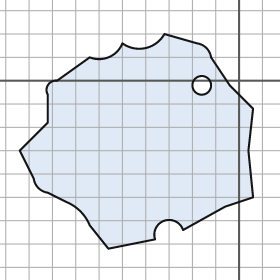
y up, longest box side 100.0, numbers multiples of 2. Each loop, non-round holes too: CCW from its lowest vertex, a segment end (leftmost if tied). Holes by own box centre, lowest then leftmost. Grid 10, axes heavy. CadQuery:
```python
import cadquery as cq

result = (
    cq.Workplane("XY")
    .moveTo(-56.0, -72.0)
    .lineTo(-36.0, -68.0)
    .threePointArc((-32.0, -60.0), (-24.0, -64.0))
    .lineTo(-6.0, -54.0)
    .lineTo(6.0, -50.0)
    .lineTo(4.0, -30.0)
    .lineTo(6.0, -12.0)
    .lineTo(-4.0, -2.0)
    .lineTo(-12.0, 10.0)
    .threePointArc((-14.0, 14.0), (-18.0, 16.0))
    .lineTo(-32.0, 20.0)
    .threePointArc((-40.0, 14.0), (-50.0, 16.0))
    .threePointArc((-56.0, 10.0), (-64.0, 10.0))
    .lineTo(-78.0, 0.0)
    .threePointArc((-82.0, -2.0), (-82.0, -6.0))
    .lineTo(-82.0, -18.0)
    .lineTo(-94.0, -30.0)
    .lineTo(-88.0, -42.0)
    .threePointArc((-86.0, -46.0), (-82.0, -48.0))
    .lineTo(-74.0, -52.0)
    .threePointArc((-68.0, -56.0), (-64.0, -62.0))
    .close()
    .moveTo(-16.0, -2.0)
    .circle(4.0)
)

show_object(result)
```